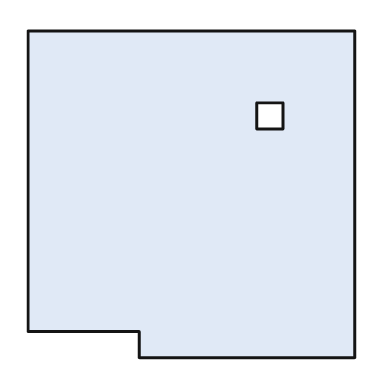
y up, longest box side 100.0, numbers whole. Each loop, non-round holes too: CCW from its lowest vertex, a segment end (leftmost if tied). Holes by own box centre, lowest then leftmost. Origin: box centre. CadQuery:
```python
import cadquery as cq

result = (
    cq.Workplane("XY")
    .moveTo(-16.0, -50.0)
    .lineTo(50.0, -50.0)
    .lineTo(50.0, 50.0)
    .lineTo(-50.0, 50.0)
    .lineTo(-50.0, -42.0)
    .lineTo(-16.0, -42.0)
    .close()
    .moveTo(20.0, 20.0)
    .lineTo(28.0, 20.0)
    .lineTo(28.0, 28.0)
    .lineTo(20.0, 28.0)
    .close()
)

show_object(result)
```